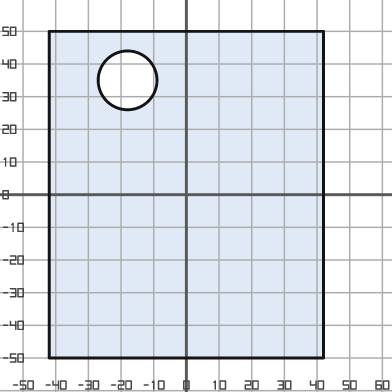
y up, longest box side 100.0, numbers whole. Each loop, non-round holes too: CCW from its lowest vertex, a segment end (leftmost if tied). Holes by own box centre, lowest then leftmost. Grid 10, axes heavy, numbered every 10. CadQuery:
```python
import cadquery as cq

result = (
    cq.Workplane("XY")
    .moveTo(-42.0, -50.0)
    .lineTo(42.0, -50.0)
    .lineTo(42.0, 50.0)
    .lineTo(-42.0, 50.0)
    .close()
    .moveTo(-18.0, 35.0)
    .circle(9.0)
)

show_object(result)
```